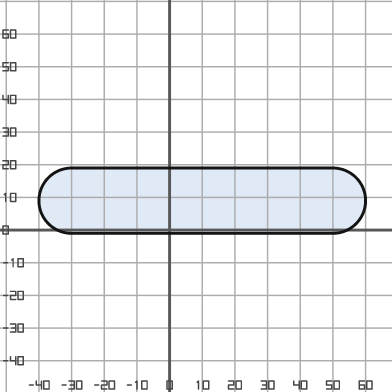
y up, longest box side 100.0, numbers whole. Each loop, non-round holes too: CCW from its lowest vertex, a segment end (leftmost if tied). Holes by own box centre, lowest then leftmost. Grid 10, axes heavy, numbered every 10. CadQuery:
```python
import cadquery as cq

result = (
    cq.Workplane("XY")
    .moveTo(-30.0, -1.0)
    .lineTo(50.0, -1.0)
    .threePointArc((60.0, 9.0), (50.0, 19.0))
    .lineTo(-30.0, 19.0)
    .threePointArc((-40.0, 9.0), (-30.0, -1.0))
    .close()
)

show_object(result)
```